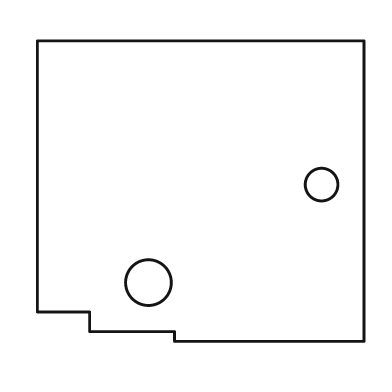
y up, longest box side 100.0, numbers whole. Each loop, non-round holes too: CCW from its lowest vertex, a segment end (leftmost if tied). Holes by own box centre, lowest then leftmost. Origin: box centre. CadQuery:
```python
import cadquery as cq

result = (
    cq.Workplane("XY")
    .moveTo(-8.0, -46.0)
    .lineTo(50.0, -46.0)
    .lineTo(50.0, 46.0)
    .lineTo(-50.0, 46.0)
    .lineTo(-50.0, -37.0)
    .lineTo(-34.0, -37.0)
    .lineTo(-34.0, -43.0)
    .lineTo(-8.0, -43.0)
    .close()
    .moveTo(-16.0, -28.0)
    .circle(7.0)
    .moveTo(37.0, 2.0)
    .circle(5.0)
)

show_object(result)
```